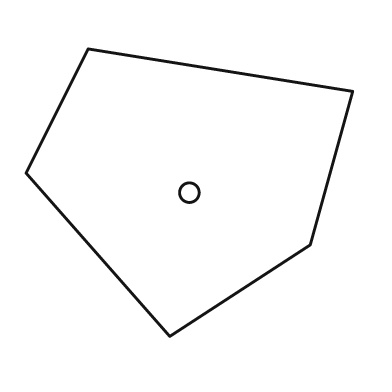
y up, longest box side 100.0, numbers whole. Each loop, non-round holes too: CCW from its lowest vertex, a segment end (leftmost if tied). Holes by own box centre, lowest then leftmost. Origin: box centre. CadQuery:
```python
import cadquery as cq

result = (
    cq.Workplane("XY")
    .moveTo(-6.0, -44.0)
    .lineTo(37.0, -16.0)
    .lineTo(50.0, 31.0)
    .lineTo(-31.0, 44.0)
    .lineTo(-50.0, 6.0)
    .close()
    .moveTo(0.0, 0.0)
    .circle(3.0)
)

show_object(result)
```